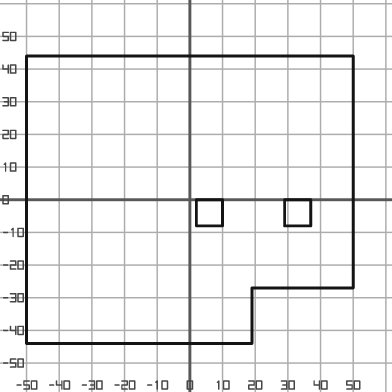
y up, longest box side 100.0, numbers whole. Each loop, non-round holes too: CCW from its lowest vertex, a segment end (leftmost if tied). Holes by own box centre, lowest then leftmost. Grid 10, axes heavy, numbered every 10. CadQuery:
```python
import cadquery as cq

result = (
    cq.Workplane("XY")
    .moveTo(-50.0, -44.0)
    .lineTo(19.0, -44.0)
    .lineTo(19.0, -27.0)
    .lineTo(50.0, -27.0)
    .lineTo(50.0, 44.0)
    .lineTo(-50.0, 44.0)
    .close()
    .moveTo(2.0, -8.0)
    .lineTo(10.0, -8.0)
    .lineTo(10.0, 0.0)
    .lineTo(2.0, 0.0)
    .close()
    .moveTo(29.0, -8.0)
    .lineTo(37.0, -8.0)
    .lineTo(37.0, 0.0)
    .lineTo(29.0, 0.0)
    .close()
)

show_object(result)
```